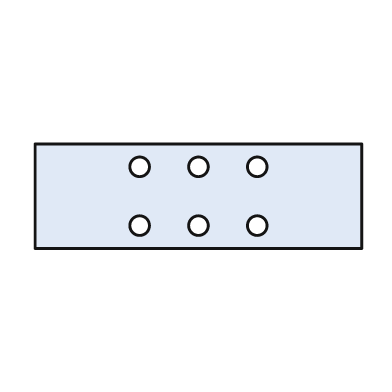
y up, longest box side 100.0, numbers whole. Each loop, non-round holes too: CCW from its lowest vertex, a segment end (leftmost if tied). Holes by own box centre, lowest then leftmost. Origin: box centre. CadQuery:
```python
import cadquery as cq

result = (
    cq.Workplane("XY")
    .moveTo(-50.0, -16.0)
    .lineTo(50.0, -16.0)
    .lineTo(50.0, 16.0)
    .lineTo(-50.0, 16.0)
    .close()
    .moveTo(-18.0, -9.0)
    .circle(3.0)
    .moveTo(0.0, -9.0)
    .circle(3.0)
    .moveTo(18.0, -9.0)
    .circle(3.0)
    .moveTo(-18.0, 9.0)
    .circle(3.0)
    .moveTo(0.0, 9.0)
    .circle(3.0)
    .moveTo(18.0, 9.0)
    .circle(3.0)
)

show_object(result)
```